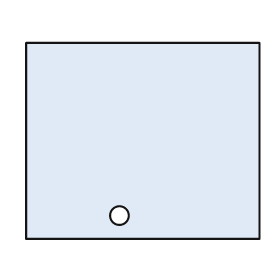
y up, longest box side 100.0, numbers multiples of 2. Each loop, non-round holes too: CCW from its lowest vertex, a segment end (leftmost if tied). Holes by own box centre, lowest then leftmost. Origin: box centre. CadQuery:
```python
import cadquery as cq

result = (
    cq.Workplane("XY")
    .moveTo(-50.0, -42.0)
    .lineTo(50.0, -42.0)
    .lineTo(50.0, 42.0)
    .lineTo(-50.0, 42.0)
    .close()
    .moveTo(-10.0, -32.0)
    .circle(4.0)
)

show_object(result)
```